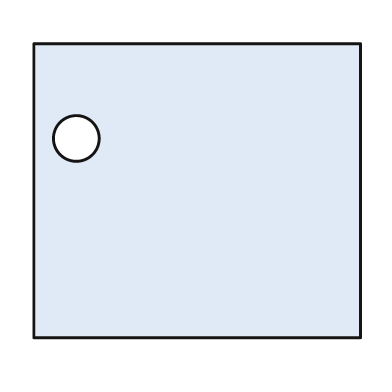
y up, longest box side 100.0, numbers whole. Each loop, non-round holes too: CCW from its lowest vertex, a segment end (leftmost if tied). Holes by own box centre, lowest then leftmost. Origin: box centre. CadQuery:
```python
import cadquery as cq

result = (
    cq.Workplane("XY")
    .moveTo(-50.0, -45.0)
    .lineTo(50.0, -45.0)
    .lineTo(50.0, 45.0)
    .lineTo(-50.0, 45.0)
    .close()
    .moveTo(-37.0, 16.0)
    .circle(7.0)
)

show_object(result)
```